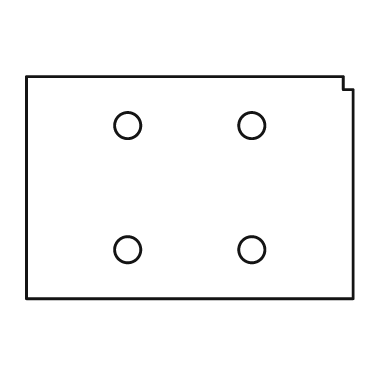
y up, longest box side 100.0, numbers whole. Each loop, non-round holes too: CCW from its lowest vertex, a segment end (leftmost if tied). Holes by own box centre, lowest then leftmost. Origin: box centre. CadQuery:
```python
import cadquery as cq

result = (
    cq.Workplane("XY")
    .moveTo(-50.0, -34.0)
    .lineTo(50.0, -34.0)
    .lineTo(50.0, 30.0)
    .lineTo(47.0, 30.0)
    .lineTo(47.0, 34.0)
    .lineTo(-50.0, 34.0)
    .close()
    .moveTo(-19.0, -19.0)
    .circle(4.0)
    .moveTo(19.0, -19.0)
    .circle(4.0)
    .moveTo(-19.0, 19.0)
    .circle(4.0)
    .moveTo(19.0, 19.0)
    .circle(4.0)
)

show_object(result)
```